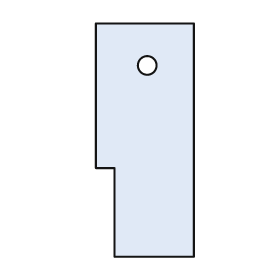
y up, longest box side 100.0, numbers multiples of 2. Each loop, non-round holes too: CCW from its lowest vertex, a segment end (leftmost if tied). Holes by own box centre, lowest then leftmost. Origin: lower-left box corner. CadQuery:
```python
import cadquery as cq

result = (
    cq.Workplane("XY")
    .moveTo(8.0, 0.0)
    .lineTo(42.0, 0.0)
    .lineTo(42.0, 100.0)
    .lineTo(0.0, 100.0)
    .lineTo(0.0, 38.0)
    .lineTo(8.0, 38.0)
    .close()
    .moveTo(22.0, 82.0)
    .circle(4.0)
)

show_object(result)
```